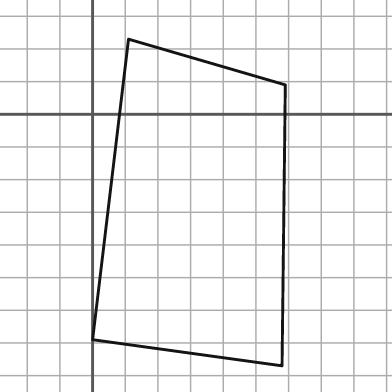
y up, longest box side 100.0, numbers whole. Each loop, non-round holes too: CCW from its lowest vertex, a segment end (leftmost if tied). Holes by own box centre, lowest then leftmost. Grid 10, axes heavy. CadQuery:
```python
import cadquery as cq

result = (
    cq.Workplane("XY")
    .moveTo(58.0, -77.0)
    .lineTo(59.0, 9.0)
    .lineTo(11.0, 23.0)
    .lineTo(0.0, -69.0)
    .close()
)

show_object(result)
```